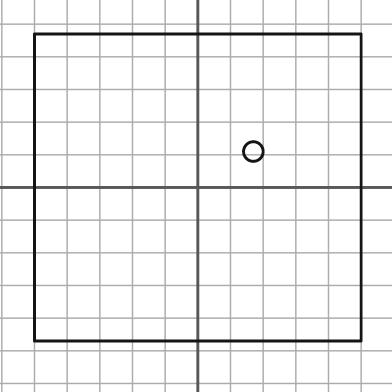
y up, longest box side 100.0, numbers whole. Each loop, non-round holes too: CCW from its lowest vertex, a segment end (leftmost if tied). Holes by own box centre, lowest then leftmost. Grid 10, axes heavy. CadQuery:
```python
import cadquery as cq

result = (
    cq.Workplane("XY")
    .moveTo(-50.0, -47.0)
    .lineTo(50.0, -47.0)
    .lineTo(50.0, 47.0)
    .lineTo(-50.0, 47.0)
    .close()
    .moveTo(17.0, 11.0)
    .circle(3.0)
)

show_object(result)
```